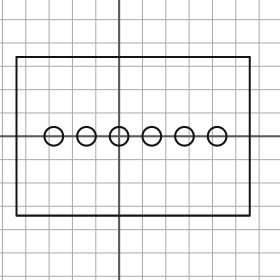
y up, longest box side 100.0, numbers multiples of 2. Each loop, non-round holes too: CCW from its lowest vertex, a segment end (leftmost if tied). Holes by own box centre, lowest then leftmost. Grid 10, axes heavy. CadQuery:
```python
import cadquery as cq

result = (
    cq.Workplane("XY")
    .moveTo(-44.0, -34.0)
    .lineTo(56.0, -34.0)
    .lineTo(56.0, 34.0)
    .lineTo(-44.0, 34.0)
    .close()
    .moveTo(-28.0, 0.0)
    .circle(4.0)
    .moveTo(-14.0, 0.0)
    .circle(4.0)
    .moveTo(0.0, 0.0)
    .circle(4.0)
    .moveTo(14.0, 0.0)
    .circle(4.0)
    .moveTo(28.0, 0.0)
    .circle(4.0)
    .moveTo(42.0, 0.0)
    .circle(4.0)
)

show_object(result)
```